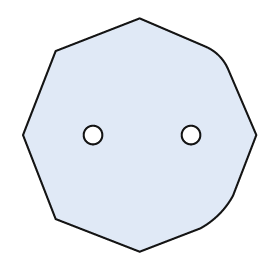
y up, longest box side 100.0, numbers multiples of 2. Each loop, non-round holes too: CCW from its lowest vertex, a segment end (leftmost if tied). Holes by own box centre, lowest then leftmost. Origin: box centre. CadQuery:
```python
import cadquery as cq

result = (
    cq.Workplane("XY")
    .moveTo(0.0, -50.0)
    .lineTo(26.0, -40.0)
    .threePointArc((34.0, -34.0), (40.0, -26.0))
    .lineTo(50.0, 0.0)
    .lineTo(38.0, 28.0)
    .threePointArc((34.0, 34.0), (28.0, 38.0))
    .lineTo(0.0, 50.0)
    .lineTo(-36.0, 36.0)
    .lineTo(-50.0, 0.0)
    .lineTo(-36.0, -36.0)
    .close()
    .moveTo(-20.0, 0.0)
    .circle(4.0)
    .moveTo(22.0, 0.0)
    .circle(4.0)
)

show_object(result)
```